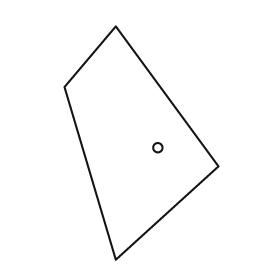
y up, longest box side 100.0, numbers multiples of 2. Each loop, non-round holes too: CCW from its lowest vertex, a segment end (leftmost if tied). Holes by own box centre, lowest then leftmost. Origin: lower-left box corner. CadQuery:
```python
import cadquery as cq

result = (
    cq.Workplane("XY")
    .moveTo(22.0, 0.0)
    .lineTo(66.0, 40.0)
    .lineTo(22.0, 100.0)
    .lineTo(0.0, 74.0)
    .close()
    .moveTo(40.0, 48.0)
    .circle(2.0)
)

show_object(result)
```